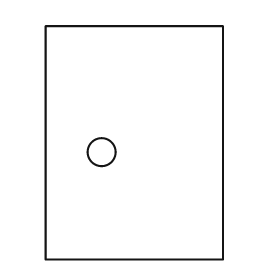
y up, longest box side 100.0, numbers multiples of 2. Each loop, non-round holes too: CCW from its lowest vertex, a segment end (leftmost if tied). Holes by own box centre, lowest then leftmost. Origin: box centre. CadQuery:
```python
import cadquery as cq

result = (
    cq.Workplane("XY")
    .moveTo(-38.0, -50.0)
    .lineTo(38.0, -50.0)
    .lineTo(38.0, 50.0)
    .lineTo(-38.0, 50.0)
    .close()
    .moveTo(-14.0, -4.0)
    .circle(6.0)
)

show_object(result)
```